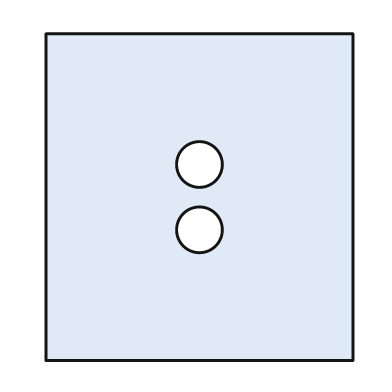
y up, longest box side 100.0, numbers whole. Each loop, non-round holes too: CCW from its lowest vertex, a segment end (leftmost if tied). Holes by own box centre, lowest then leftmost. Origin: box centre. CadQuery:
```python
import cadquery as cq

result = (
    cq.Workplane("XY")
    .moveTo(-47.0, -50.0)
    .lineTo(47.0, -50.0)
    .lineTo(47.0, 50.0)
    .lineTo(-47.0, 50.0)
    .close()
    .moveTo(0.0, -10.0)
    .circle(7.0)
    .moveTo(0.0, 10.0)
    .circle(7.0)
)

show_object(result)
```